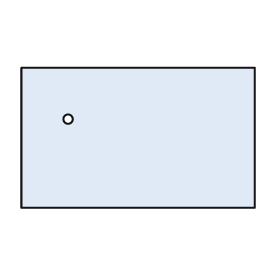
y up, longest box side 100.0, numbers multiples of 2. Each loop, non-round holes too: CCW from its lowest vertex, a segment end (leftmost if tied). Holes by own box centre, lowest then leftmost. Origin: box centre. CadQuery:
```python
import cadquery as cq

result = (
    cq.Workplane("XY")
    .moveTo(-50.0, -30.0)
    .lineTo(50.0, -30.0)
    .lineTo(50.0, 30.0)
    .lineTo(-50.0, 30.0)
    .close()
    .moveTo(-30.0, 8.0)
    .circle(2.0)
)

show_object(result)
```